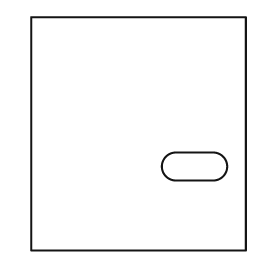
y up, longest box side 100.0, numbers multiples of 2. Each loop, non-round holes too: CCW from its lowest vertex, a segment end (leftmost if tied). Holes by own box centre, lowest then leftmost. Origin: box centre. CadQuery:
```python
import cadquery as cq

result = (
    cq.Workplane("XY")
    .moveTo(-46.0, -50.0)
    .lineTo(46.0, -50.0)
    .lineTo(46.0, 50.0)
    .lineTo(-46.0, 50.0)
    .close()
    .moveTo(16.0, -20.0)
    .lineTo(32.0, -20.0)
    .threePointArc((38.0, -14.0), (32.0, -8.0))
    .lineTo(16.0, -8.0)
    .threePointArc((10.0, -14.0), (16.0, -20.0))
    .close()
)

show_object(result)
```